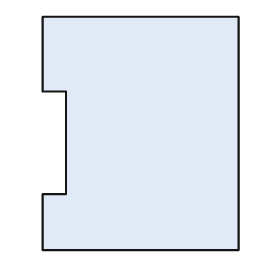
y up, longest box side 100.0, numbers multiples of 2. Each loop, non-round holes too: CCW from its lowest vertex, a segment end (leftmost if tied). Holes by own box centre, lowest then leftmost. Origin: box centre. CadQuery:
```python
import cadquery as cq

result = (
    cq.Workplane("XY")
    .moveTo(-42.0, -50.0)
    .lineTo(42.0, -50.0)
    .lineTo(42.0, 50.0)
    .lineTo(-42.0, 50.0)
    .lineTo(-42.0, 18.0)
    .lineTo(-32.0, 18.0)
    .lineTo(-32.0, -26.0)
    .lineTo(-42.0, -26.0)
    .close()
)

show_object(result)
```